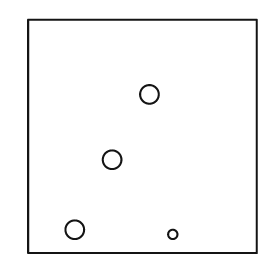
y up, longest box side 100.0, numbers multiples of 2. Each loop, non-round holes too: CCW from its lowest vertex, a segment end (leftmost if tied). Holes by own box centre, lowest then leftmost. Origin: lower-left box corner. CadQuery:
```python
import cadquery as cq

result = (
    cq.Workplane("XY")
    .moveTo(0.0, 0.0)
    .lineTo(98.0, 0.0)
    .lineTo(98.0, 100.0)
    .lineTo(0.0, 100.0)
    .close()
    .moveTo(62.0, 8.0)
    .circle(2.0)
    .moveTo(20.0, 10.0)
    .circle(4.0)
    .moveTo(36.0, 40.0)
    .circle(4.0)
    .moveTo(52.0, 68.0)
    .circle(4.0)
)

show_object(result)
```